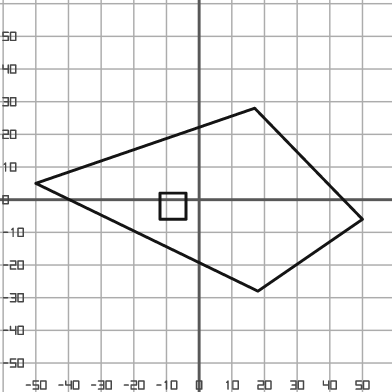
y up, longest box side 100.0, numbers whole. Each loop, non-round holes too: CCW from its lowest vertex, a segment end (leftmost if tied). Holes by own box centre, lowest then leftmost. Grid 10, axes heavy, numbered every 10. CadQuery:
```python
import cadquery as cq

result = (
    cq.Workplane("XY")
    .moveTo(18.0, -28.0)
    .lineTo(50.0, -6.0)
    .lineTo(17.0, 28.0)
    .lineTo(-50.0, 5.0)
    .close()
    .moveTo(-12.0, -6.0)
    .lineTo(-4.0, -6.0)
    .lineTo(-4.0, 2.0)
    .lineTo(-12.0, 2.0)
    .close()
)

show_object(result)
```